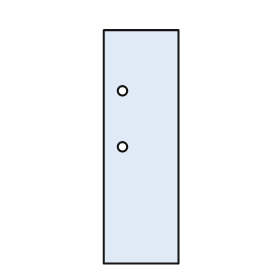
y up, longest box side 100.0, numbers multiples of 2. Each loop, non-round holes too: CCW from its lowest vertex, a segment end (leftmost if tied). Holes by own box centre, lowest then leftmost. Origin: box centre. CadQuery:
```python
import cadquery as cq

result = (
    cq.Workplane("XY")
    .moveTo(-16.0, -50.0)
    .lineTo(16.0, -50.0)
    .lineTo(16.0, 50.0)
    .lineTo(-16.0, 50.0)
    .close()
    .moveTo(-8.0, 0.0)
    .circle(2.0)
    .moveTo(-8.0, 24.0)
    .circle(2.0)
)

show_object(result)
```